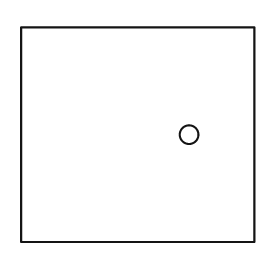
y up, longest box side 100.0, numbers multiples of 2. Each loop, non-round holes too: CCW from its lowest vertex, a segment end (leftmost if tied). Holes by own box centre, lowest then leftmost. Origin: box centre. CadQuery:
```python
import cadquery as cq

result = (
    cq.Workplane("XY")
    .moveTo(-50.0, -46.0)
    .lineTo(50.0, -46.0)
    .lineTo(50.0, 46.0)
    .lineTo(-50.0, 46.0)
    .close()
    .moveTo(22.0, 0.0)
    .circle(4.0)
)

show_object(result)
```